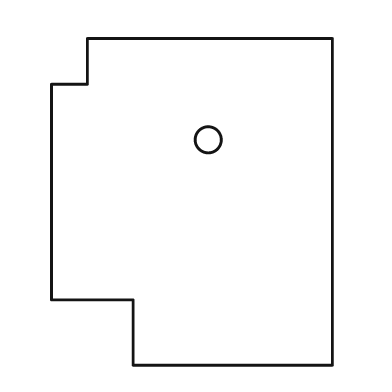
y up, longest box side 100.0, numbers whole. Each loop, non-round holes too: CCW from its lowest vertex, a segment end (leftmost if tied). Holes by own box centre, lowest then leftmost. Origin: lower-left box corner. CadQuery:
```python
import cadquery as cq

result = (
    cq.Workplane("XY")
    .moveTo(25.0, 0.0)
    .lineTo(86.0, 0.0)
    .lineTo(86.0, 100.0)
    .lineTo(11.0, 100.0)
    .lineTo(11.0, 86.0)
    .lineTo(0.0, 86.0)
    .lineTo(0.0, 20.0)
    .lineTo(25.0, 20.0)
    .close()
    .moveTo(48.0, 69.0)
    .circle(4.0)
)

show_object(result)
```